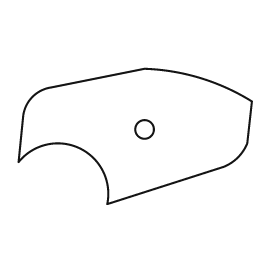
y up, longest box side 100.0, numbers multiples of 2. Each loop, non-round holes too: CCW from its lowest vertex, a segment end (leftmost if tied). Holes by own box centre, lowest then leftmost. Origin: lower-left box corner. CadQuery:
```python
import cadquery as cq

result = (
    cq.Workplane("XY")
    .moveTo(38.0, 0.0)
    .lineTo(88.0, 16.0)
    .threePointArc((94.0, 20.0), (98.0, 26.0))
    .lineTo(100.0, 44.0)
    .threePointArc((78.0, 54.0), (54.0, 58.0))
    .lineTo(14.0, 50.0)
    .threePointArc((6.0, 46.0), (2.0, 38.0))
    .lineTo(0.0, 18.0)
    .threePointArc((26.0, 24.0), (38.0, 0.0))
    .close()
    .moveTo(54.0, 32.0)
    .circle(4.0)
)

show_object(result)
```